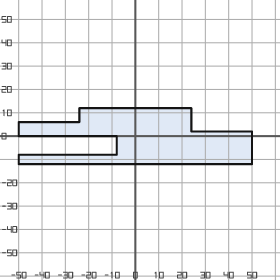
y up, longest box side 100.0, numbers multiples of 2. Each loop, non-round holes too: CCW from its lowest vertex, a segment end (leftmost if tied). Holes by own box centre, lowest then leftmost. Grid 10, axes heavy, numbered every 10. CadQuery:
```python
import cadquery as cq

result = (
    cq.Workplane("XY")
    .moveTo(-50.0, -12.0)
    .lineTo(50.0, -12.0)
    .lineTo(50.0, 2.0)
    .lineTo(24.0, 2.0)
    .lineTo(24.0, 12.0)
    .lineTo(-24.0, 12.0)
    .lineTo(-24.0, 6.0)
    .lineTo(-50.0, 6.0)
    .lineTo(-50.0, 0.0)
    .lineTo(-8.0, 0.0)
    .lineTo(-8.0, -8.0)
    .lineTo(-50.0, -8.0)
    .close()
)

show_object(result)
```